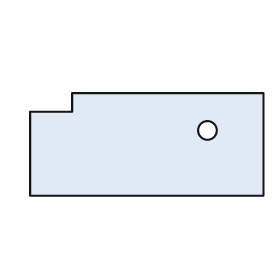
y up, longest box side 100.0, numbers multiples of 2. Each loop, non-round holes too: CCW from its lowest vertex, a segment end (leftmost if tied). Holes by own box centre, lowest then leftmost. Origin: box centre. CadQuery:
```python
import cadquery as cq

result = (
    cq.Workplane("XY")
    .moveTo(-50.0, -22.0)
    .lineTo(50.0, -22.0)
    .lineTo(50.0, 22.0)
    .lineTo(-32.0, 22.0)
    .lineTo(-32.0, 14.0)
    .lineTo(-50.0, 14.0)
    .close()
    .moveTo(26.0, 6.0)
    .circle(4.0)
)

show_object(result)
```